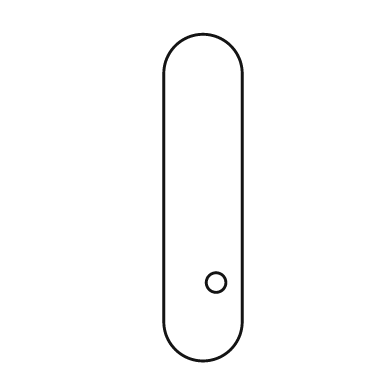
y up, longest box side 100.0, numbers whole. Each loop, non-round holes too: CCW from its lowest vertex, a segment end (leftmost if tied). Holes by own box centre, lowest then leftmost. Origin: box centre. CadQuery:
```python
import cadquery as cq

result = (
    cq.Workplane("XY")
    .moveTo(-12.0, -38.0)
    .threePointArc((0.0, -50.0), (12.0, -38.0))
    .lineTo(12.0, 38.0)
    .threePointArc((0.0, 50.0), (-12.0, 38.0))
    .close()
    .moveTo(4.0, -26.0)
    .circle(3.0)
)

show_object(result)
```